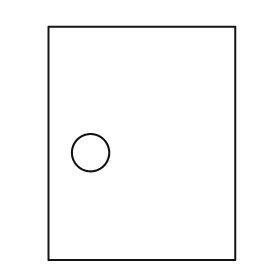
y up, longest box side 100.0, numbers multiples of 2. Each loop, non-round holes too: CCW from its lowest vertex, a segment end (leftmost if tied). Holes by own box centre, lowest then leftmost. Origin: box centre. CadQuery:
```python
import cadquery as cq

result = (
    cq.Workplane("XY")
    .moveTo(-40.0, -50.0)
    .lineTo(40.0, -50.0)
    .lineTo(40.0, 50.0)
    .lineTo(-40.0, 50.0)
    .close()
    .moveTo(-22.0, -4.0)
    .circle(8.0)
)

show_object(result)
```